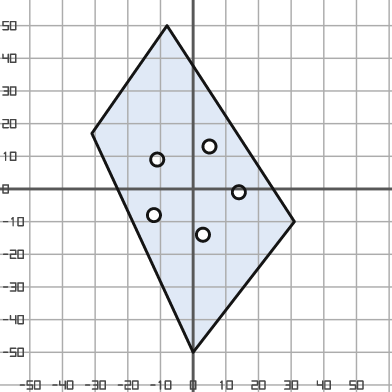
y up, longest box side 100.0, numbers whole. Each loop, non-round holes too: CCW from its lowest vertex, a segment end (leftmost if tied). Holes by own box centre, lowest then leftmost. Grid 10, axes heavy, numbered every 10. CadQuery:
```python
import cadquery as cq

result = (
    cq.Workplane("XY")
    .moveTo(0.0, -50.0)
    .lineTo(31.0, -10.0)
    .lineTo(-8.0, 50.0)
    .lineTo(-31.0, 17.0)
    .close()
    .moveTo(3.0, -14.0)
    .circle(2.0)
    .moveTo(-12.0, -8.0)
    .circle(2.0)
    .moveTo(14.0, -1.0)
    .circle(2.0)
    .moveTo(-11.0, 9.0)
    .circle(2.0)
    .moveTo(5.0, 13.0)
    .circle(2.0)
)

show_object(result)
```